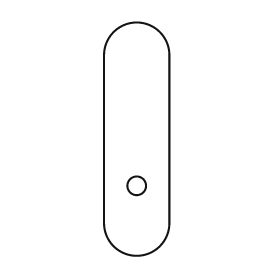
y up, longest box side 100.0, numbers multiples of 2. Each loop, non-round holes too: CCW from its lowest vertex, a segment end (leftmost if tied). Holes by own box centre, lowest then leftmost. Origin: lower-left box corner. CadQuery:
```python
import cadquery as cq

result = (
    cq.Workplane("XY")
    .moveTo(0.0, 14.0)
    .threePointArc((14.0, 0.0), (28.0, 14.0))
    .lineTo(28.0, 86.0)
    .threePointArc((14.0, 100.0), (0.0, 86.0))
    .close()
    .moveTo(14.0, 30.0)
    .circle(4.0)
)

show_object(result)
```